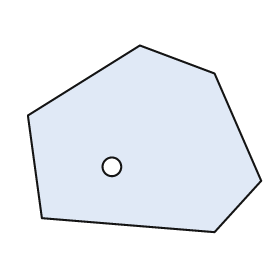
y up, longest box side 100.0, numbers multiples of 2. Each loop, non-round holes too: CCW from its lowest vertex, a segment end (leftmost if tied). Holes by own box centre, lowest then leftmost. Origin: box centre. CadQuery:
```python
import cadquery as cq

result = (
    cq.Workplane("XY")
    .moveTo(30.0, -40.0)
    .lineTo(50.0, -18.0)
    .lineTo(30.0, 28.0)
    .lineTo(-2.0, 40.0)
    .lineTo(-50.0, 10.0)
    .lineTo(-44.0, -34.0)
    .close()
    .moveTo(-14.0, -12.0)
    .circle(4.0)
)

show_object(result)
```